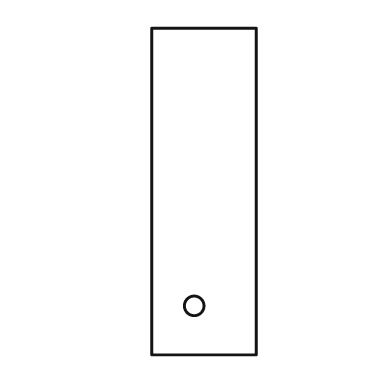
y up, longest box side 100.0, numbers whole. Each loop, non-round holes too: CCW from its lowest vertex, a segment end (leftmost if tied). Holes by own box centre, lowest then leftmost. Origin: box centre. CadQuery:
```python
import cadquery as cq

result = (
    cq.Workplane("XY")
    .moveTo(-16.0, -50.0)
    .lineTo(16.0, -50.0)
    .lineTo(16.0, 50.0)
    .lineTo(-16.0, 50.0)
    .close()
    .moveTo(-3.0, -35.0)
    .circle(3.0)
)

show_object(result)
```